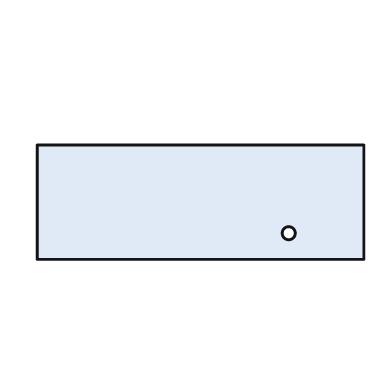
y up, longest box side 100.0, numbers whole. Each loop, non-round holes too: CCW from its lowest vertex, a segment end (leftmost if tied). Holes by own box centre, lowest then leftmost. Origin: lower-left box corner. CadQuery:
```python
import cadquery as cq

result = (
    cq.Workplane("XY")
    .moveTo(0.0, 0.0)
    .lineTo(100.0, 0.0)
    .lineTo(100.0, 35.0)
    .lineTo(0.0, 35.0)
    .close()
    .moveTo(77.0, 8.0)
    .circle(2.0)
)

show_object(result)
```